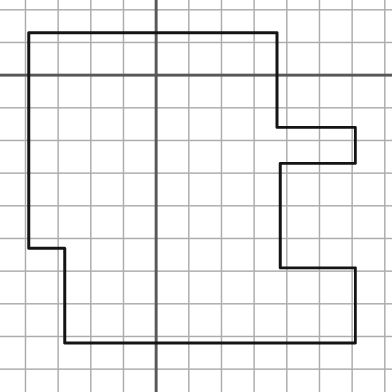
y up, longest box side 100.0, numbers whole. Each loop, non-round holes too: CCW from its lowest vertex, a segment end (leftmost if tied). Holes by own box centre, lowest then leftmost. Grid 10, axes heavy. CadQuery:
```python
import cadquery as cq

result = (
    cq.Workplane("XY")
    .moveTo(-28.0, -82.0)
    .lineTo(61.0, -82.0)
    .lineTo(61.0, -59.0)
    .lineTo(38.0, -59.0)
    .lineTo(38.0, -27.0)
    .lineTo(61.0, -27.0)
    .lineTo(61.0, -16.0)
    .lineTo(37.0, -16.0)
    .lineTo(37.0, 13.0)
    .lineTo(-39.0, 13.0)
    .lineTo(-39.0, -53.0)
    .lineTo(-28.0, -53.0)
    .close()
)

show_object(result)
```